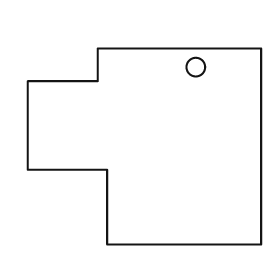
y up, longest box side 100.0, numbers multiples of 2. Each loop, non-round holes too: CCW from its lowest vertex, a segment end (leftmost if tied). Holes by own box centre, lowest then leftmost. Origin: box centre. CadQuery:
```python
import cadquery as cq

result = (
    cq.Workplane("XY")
    .moveTo(-16.0, -42.0)
    .lineTo(50.0, -42.0)
    .lineTo(50.0, 42.0)
    .lineTo(-20.0, 42.0)
    .lineTo(-20.0, 28.0)
    .lineTo(-50.0, 28.0)
    .lineTo(-50.0, -10.0)
    .lineTo(-16.0, -10.0)
    .close()
    .moveTo(22.0, 34.0)
    .circle(4.0)
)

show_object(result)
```